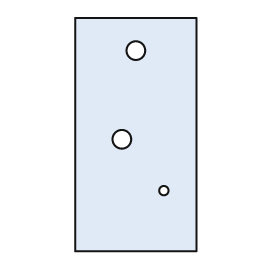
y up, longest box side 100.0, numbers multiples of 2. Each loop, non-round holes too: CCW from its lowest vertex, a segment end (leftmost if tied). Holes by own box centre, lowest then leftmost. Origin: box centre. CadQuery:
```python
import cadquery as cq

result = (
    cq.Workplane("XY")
    .moveTo(-26.0, -50.0)
    .lineTo(26.0, -50.0)
    .lineTo(26.0, 50.0)
    .lineTo(-26.0, 50.0)
    .close()
    .moveTo(12.0, -24.0)
    .circle(2.0)
    .moveTo(-6.0, -2.0)
    .circle(4.0)
    .moveTo(0.0, 36.0)
    .circle(4.0)
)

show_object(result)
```